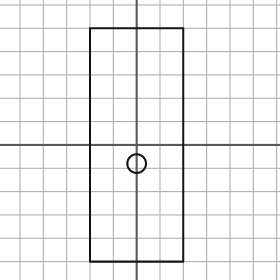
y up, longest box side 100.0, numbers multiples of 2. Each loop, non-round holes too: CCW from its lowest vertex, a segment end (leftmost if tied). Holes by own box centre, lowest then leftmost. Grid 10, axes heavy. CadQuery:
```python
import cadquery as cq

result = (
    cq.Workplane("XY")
    .moveTo(-20.0, -50.0)
    .lineTo(20.0, -50.0)
    .lineTo(20.0, 50.0)
    .lineTo(-20.0, 50.0)
    .close()
    .moveTo(0.0, -8.0)
    .circle(4.0)
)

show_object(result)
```